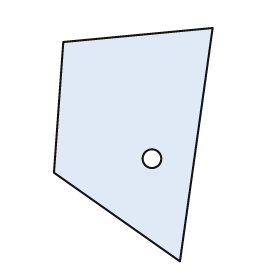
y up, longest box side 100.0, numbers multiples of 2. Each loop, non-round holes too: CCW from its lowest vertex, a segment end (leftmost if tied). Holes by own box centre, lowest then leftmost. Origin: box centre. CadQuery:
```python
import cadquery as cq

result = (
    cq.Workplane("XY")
    .moveTo(20.0, -50.0)
    .lineTo(34.0, 50.0)
    .lineTo(-30.0, 44.0)
    .lineTo(-34.0, -12.0)
    .close()
    .moveTo(8.0, -6.0)
    .circle(4.0)
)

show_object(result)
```